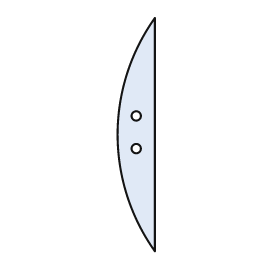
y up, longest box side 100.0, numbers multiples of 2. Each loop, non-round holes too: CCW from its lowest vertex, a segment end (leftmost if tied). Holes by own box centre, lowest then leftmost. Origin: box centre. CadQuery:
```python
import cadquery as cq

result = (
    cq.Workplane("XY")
    .moveTo(8.0, -50.0)
    .lineTo(8.0, 50.0)
    .threePointArc((-8.0, 0.0), (8.0, -50.0))
    .close()
    .moveTo(0.0, -6.0)
    .circle(2.0)
    .moveTo(0.0, 8.0)
    .circle(2.0)
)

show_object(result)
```